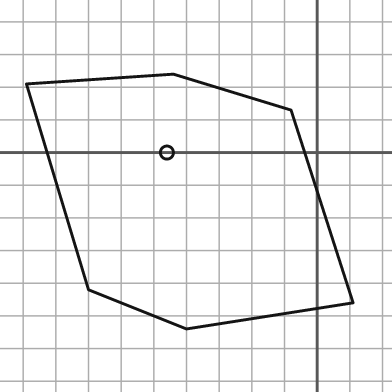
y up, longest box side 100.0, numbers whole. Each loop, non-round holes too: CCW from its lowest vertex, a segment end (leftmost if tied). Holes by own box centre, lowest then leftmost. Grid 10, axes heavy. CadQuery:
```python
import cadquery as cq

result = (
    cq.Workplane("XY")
    .moveTo(-40.0, -54.0)
    .lineTo(11.0, -46.0)
    .lineTo(-8.0, 13.0)
    .lineTo(-44.0, 24.0)
    .lineTo(-89.0, 21.0)
    .lineTo(-70.0, -42.0)
    .close()
    .moveTo(-46.0, 0.0)
    .circle(2.0)
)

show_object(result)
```